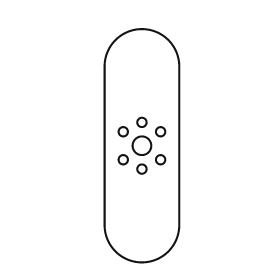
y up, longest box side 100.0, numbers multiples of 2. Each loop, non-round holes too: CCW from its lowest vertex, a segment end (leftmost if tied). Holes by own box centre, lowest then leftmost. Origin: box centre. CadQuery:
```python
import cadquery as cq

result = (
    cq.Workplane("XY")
    .moveTo(-16.0, -34.0)
    .threePointArc((0.0, -50.0), (16.0, -34.0))
    .lineTo(16.0, 34.0)
    .threePointArc((0.0, 50.0), (-16.0, 34.0))
    .close()
    .moveTo(0.0, -10.0)
    .circle(2.0)
    .moveTo(-8.0, -6.0)
    .circle(2.0)
    .moveTo(8.0, -6.0)
    .circle(2.0)
    .moveTo(0.0, 0.0)
    .circle(4.0)
    .moveTo(-8.0, 6.0)
    .circle(2.0)
    .moveTo(8.0, 6.0)
    .circle(2.0)
    .moveTo(0.0, 10.0)
    .circle(2.0)
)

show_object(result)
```